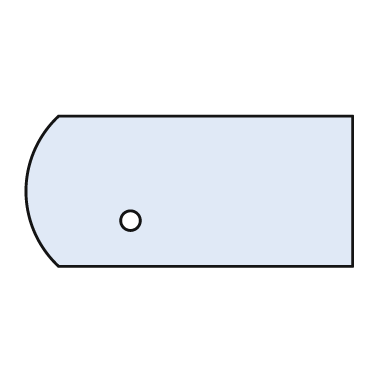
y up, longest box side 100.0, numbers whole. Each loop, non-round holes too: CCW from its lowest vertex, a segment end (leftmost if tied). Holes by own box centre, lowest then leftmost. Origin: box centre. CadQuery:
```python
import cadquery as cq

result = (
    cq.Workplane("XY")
    .moveTo(-40.0, -23.0)
    .lineTo(50.0, -23.0)
    .lineTo(50.0, 23.0)
    .lineTo(-40.0, 23.0)
    .threePointArc((-50.0, 0.0), (-40.0, -23.0))
    .close()
    .moveTo(-18.0, -9.0)
    .circle(3.0)
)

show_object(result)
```